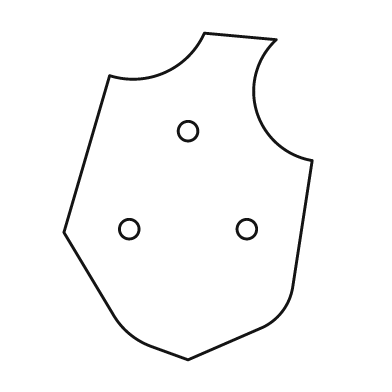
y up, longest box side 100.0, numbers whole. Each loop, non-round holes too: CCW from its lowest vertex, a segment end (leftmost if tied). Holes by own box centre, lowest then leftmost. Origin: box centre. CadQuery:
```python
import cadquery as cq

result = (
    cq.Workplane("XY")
    .moveTo(0.0, -50.0)
    .lineTo(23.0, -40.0)
    .threePointArc((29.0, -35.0), (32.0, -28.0))
    .lineTo(38.0, 11.0)
    .threePointArc((21.0, 26.0), (27.0, 48.0))
    .lineTo(5.0, 50.0)
    .threePointArc((-7.0, 38.0), (-24.0, 37.0))
    .lineTo(-38.0, -11.0)
    .lineTo(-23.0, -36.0)
    .threePointArc((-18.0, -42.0), (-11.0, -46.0))
    .close()
    .moveTo(-18.0, -10.0)
    .circle(3.0)
    .moveTo(18.0, -10.0)
    .circle(3.0)
    .moveTo(0.0, 20.0)
    .circle(3.0)
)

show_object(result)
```